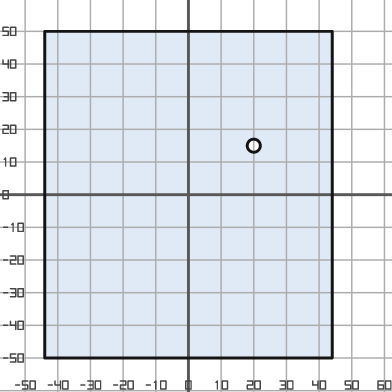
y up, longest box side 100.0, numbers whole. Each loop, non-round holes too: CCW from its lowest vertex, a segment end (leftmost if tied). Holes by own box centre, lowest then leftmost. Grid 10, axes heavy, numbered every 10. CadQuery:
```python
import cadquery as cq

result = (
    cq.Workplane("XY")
    .moveTo(-44.0, -50.0)
    .lineTo(44.0, -50.0)
    .lineTo(44.0, 50.0)
    .lineTo(-44.0, 50.0)
    .close()
    .moveTo(20.0, 15.0)
    .circle(2.0)
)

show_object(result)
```